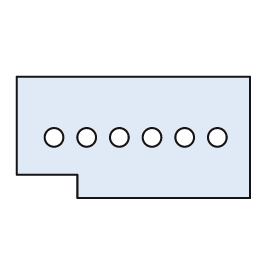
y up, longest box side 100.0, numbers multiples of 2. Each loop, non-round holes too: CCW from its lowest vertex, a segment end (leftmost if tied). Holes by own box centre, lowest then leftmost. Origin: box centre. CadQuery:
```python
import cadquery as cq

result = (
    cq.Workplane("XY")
    .moveTo(-24.0, -26.0)
    .lineTo(50.0, -26.0)
    .lineTo(50.0, 26.0)
    .lineTo(-50.0, 26.0)
    .lineTo(-50.0, -16.0)
    .lineTo(-24.0, -16.0)
    .close()
    .moveTo(-34.0, 0.0)
    .circle(4.0)
    .moveTo(-20.0, 0.0)
    .circle(4.0)
    .moveTo(-6.0, 0.0)
    .circle(4.0)
    .moveTo(8.0, 0.0)
    .circle(4.0)
    .moveTo(22.0, 0.0)
    .circle(4.0)
    .moveTo(36.0, 0.0)
    .circle(4.0)
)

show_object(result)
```